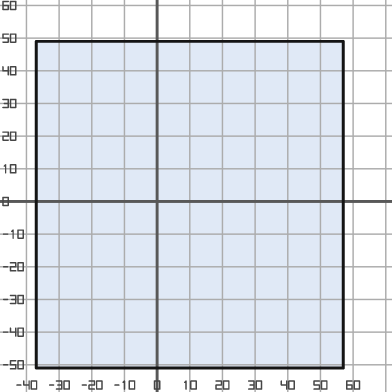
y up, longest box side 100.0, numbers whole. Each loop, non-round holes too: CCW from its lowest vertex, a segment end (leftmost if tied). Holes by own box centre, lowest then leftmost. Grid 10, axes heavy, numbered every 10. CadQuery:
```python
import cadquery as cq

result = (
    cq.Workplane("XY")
    .moveTo(-37.0, -51.0)
    .lineTo(57.0, -51.0)
    .lineTo(57.0, 49.0)
    .lineTo(-37.0, 49.0)
    .close()
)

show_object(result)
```